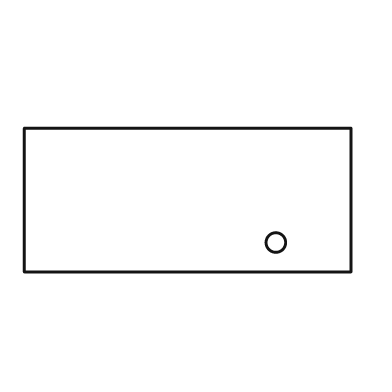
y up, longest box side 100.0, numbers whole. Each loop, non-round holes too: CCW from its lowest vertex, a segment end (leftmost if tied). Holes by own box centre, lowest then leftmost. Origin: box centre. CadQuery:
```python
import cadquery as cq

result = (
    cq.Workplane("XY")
    .moveTo(-50.0, -22.0)
    .lineTo(50.0, -22.0)
    .lineTo(50.0, 22.0)
    .lineTo(-50.0, 22.0)
    .close()
    .moveTo(27.0, -13.0)
    .circle(3.0)
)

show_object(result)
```